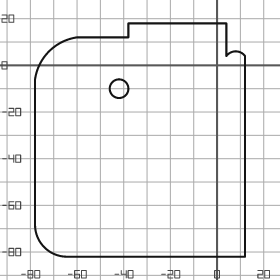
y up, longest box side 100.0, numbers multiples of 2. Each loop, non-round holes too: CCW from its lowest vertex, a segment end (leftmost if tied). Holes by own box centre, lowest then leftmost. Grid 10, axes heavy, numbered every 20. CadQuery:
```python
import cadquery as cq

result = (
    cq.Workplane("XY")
    .moveTo(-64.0, -82.0)
    .lineTo(12.0, -82.0)
    .lineTo(12.0, 4.0)
    .threePointArc((8.0, 6.0), (4.0, 4.0))
    .lineTo(4.0, 18.0)
    .lineTo(-38.0, 18.0)
    .lineTo(-38.0, 12.0)
    .lineTo(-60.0, 12.0)
    .threePointArc((-72.0, 6.0), (-78.0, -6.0))
    .lineTo(-78.0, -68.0)
    .threePointArc((-74.0, -78.0), (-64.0, -82.0))
    .close()
    .moveTo(-42.0, -10.0)
    .circle(4.0)
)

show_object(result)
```